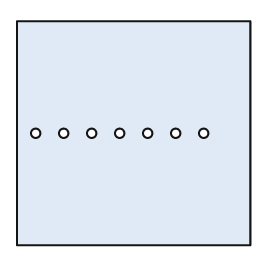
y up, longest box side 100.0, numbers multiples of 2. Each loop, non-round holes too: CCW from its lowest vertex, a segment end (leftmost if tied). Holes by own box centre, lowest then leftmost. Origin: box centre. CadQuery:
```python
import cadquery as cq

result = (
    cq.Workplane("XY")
    .moveTo(-50.0, -48.0)
    .lineTo(50.0, -48.0)
    .lineTo(50.0, 48.0)
    .lineTo(-50.0, 48.0)
    .close()
    .moveTo(-42.0, 0.0)
    .circle(2.0)
    .moveTo(-30.0, 0.0)
    .circle(2.0)
    .moveTo(-18.0, 0.0)
    .circle(2.0)
    .moveTo(-6.0, 0.0)
    .circle(2.0)
    .moveTo(6.0, 0.0)
    .circle(2.0)
    .moveTo(18.0, 0.0)
    .circle(2.0)
    .moveTo(30.0, 0.0)
    .circle(2.0)
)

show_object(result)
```